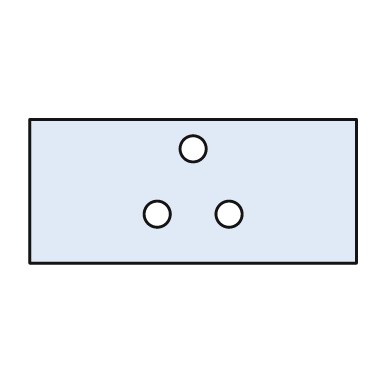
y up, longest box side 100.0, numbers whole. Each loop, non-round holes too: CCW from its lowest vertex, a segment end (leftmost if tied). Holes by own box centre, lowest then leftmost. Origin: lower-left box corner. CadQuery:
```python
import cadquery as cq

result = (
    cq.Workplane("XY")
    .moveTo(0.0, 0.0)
    .lineTo(100.0, 0.0)
    .lineTo(100.0, 44.0)
    .lineTo(0.0, 44.0)
    .close()
    .moveTo(39.0, 15.0)
    .circle(4.0)
    .moveTo(61.0, 15.0)
    .circle(4.0)
    .moveTo(50.0, 35.0)
    .circle(4.0)
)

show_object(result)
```